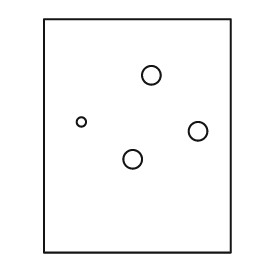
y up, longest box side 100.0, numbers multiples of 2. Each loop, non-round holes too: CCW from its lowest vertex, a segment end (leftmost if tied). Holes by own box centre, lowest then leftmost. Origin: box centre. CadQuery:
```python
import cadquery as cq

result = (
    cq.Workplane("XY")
    .moveTo(-40.0, -50.0)
    .lineTo(40.0, -50.0)
    .lineTo(40.0, 50.0)
    .lineTo(-40.0, 50.0)
    .close()
    .moveTo(-2.0, -10.0)
    .circle(4.0)
    .moveTo(26.0, 2.0)
    .circle(4.0)
    .moveTo(-24.0, 6.0)
    .circle(2.0)
    .moveTo(6.0, 26.0)
    .circle(4.0)
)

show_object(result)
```